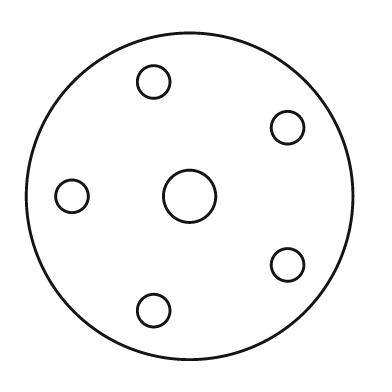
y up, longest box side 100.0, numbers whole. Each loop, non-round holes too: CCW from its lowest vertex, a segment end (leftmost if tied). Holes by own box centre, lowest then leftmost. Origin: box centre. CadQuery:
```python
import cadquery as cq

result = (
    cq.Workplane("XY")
    .moveTo(0.0, 0.0)
    .circle(50.0)
    .moveTo(-11.0, -35.0)
    .circle(5.0)
    .moveTo(30.0, -21.0)
    .circle(5.0)
    .moveTo(-36.0, 0.0)
    .circle(5.0)
    .moveTo(0.0, 0.0)
    .circle(8.0)
    .moveTo(30.0, 21.0)
    .circle(5.0)
    .moveTo(-11.0, 35.0)
    .circle(5.0)
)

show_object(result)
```